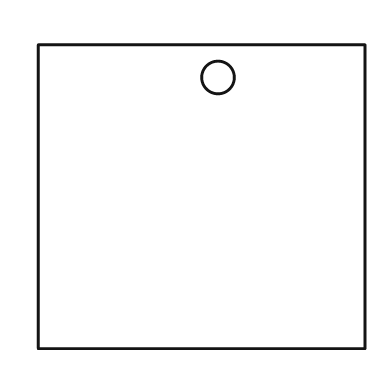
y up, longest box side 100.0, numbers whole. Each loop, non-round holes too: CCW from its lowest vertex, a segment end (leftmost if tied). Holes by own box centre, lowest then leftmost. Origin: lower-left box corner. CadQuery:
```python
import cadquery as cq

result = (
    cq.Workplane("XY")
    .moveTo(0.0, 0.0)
    .lineTo(100.0, 0.0)
    .lineTo(100.0, 93.0)
    .lineTo(0.0, 93.0)
    .close()
    .moveTo(55.0, 83.0)
    .circle(5.0)
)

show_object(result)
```